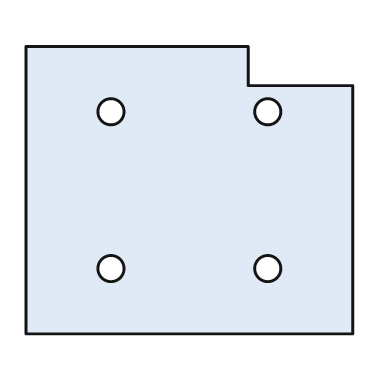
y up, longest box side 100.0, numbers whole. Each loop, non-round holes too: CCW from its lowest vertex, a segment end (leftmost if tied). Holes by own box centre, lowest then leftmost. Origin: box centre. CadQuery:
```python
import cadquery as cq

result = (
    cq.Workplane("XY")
    .moveTo(-50.0, -44.0)
    .lineTo(50.0, -44.0)
    .lineTo(50.0, 32.0)
    .lineTo(18.0, 32.0)
    .lineTo(18.0, 44.0)
    .lineTo(-50.0, 44.0)
    .close()
    .moveTo(-24.0, -24.0)
    .circle(4.0)
    .moveTo(24.0, -24.0)
    .circle(4.0)
    .moveTo(-24.0, 24.0)
    .circle(4.0)
    .moveTo(24.0, 24.0)
    .circle(4.0)
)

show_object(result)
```